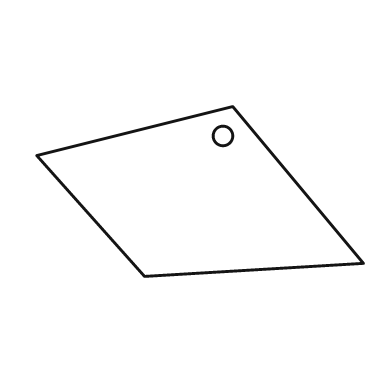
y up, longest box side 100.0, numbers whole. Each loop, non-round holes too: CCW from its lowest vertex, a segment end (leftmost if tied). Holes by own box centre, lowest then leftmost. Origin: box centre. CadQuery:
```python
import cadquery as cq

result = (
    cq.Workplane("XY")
    .moveTo(-17.0, -26.0)
    .lineTo(50.0, -22.0)
    .lineTo(10.0, 26.0)
    .lineTo(-50.0, 11.0)
    .close()
    .moveTo(7.0, 17.0)
    .circle(3.0)
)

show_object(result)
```